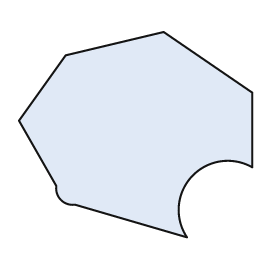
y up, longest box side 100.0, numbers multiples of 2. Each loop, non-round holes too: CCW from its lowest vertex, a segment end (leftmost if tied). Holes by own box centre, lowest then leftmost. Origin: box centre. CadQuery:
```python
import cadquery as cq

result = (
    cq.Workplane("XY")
    .moveTo(22.0, -44.0)
    .threePointArc((24.0, -18.0), (50.0, -14.0))
    .lineTo(50.0, 18.0)
    .lineTo(12.0, 44.0)
    .lineTo(-30.0, 34.0)
    .lineTo(-50.0, 6.0)
    .lineTo(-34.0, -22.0)
    .threePointArc((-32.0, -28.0), (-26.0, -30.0))
    .close()
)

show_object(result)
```